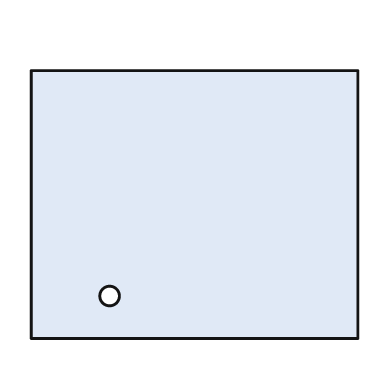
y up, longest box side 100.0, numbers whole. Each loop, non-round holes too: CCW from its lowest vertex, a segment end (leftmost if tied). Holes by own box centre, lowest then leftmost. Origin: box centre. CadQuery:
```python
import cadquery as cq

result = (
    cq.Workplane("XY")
    .moveTo(-50.0, -41.0)
    .lineTo(50.0, -41.0)
    .lineTo(50.0, 41.0)
    .lineTo(-50.0, 41.0)
    .close()
    .moveTo(-26.0, -28.0)
    .circle(3.0)
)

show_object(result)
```